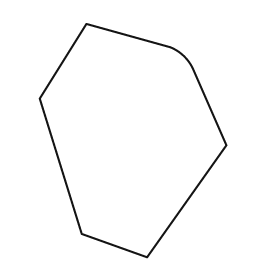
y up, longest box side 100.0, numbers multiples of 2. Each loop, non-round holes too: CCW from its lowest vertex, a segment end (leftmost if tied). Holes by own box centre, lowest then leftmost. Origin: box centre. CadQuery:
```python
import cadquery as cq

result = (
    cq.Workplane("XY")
    .moveTo(6.0, -50.0)
    .lineTo(40.0, -2.0)
    .lineTo(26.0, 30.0)
    .threePointArc((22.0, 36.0), (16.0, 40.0))
    .lineTo(-20.0, 50.0)
    .lineTo(-40.0, 18.0)
    .lineTo(-22.0, -40.0)
    .close()
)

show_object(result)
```